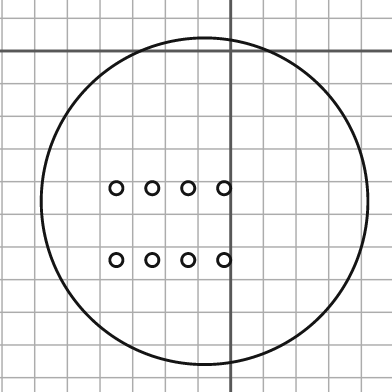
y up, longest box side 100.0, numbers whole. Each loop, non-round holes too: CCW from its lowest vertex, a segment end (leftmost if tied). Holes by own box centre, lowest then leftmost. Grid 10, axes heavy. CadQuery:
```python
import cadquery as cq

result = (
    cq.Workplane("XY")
    .moveTo(-8.0, -46.0)
    .circle(50.0)
    .moveTo(-35.0, -64.0)
    .circle(2.0)
    .moveTo(-24.0, -64.0)
    .circle(2.0)
    .moveTo(-13.0, -64.0)
    .circle(2.0)
    .moveTo(-2.0, -64.0)
    .circle(2.0)
    .moveTo(-35.0, -42.0)
    .circle(2.0)
    .moveTo(-24.0, -42.0)
    .circle(2.0)
    .moveTo(-13.0, -42.0)
    .circle(2.0)
    .moveTo(-2.0, -42.0)
    .circle(2.0)
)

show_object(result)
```